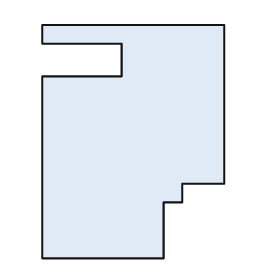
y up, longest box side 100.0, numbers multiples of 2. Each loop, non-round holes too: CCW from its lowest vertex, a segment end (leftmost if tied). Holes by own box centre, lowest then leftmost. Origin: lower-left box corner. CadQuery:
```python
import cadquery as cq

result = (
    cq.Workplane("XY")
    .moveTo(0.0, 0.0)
    .lineTo(52.0, 0.0)
    .lineTo(52.0, 24.0)
    .lineTo(60.0, 24.0)
    .lineTo(60.0, 32.0)
    .lineTo(78.0, 32.0)
    .lineTo(78.0, 100.0)
    .lineTo(0.0, 100.0)
    .lineTo(0.0, 92.0)
    .lineTo(34.0, 92.0)
    .lineTo(34.0, 78.0)
    .lineTo(0.0, 78.0)
    .close()
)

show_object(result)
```